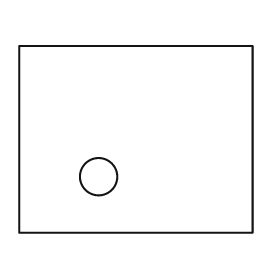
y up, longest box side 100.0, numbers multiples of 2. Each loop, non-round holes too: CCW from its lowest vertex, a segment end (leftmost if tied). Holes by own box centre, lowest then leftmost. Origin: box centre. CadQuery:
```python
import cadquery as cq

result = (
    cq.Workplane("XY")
    .moveTo(-50.0, -40.0)
    .lineTo(50.0, -40.0)
    .lineTo(50.0, 40.0)
    .lineTo(-50.0, 40.0)
    .close()
    .moveTo(-16.0, -16.0)
    .circle(8.0)
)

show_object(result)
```